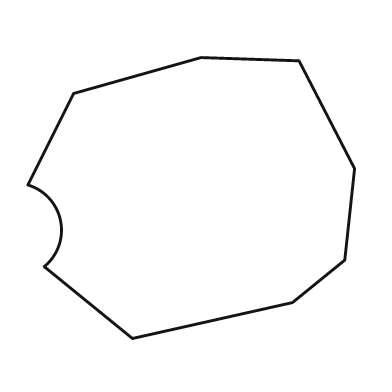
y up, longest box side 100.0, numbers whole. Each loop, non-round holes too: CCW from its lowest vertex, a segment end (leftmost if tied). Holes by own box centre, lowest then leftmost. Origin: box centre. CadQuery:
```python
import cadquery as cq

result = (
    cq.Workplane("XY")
    .moveTo(-18.0, -43.0)
    .lineTo(31.0, -32.0)
    .lineTo(47.0, -19.0)
    .lineTo(50.0, 9.0)
    .lineTo(33.0, 42.0)
    .lineTo(3.0, 43.0)
    .lineTo(-36.0, 32.0)
    .lineTo(-50.0, 4.0)
    .threePointArc((-40.0, -7.0), (-45.0, -21.0))
    .close()
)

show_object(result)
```